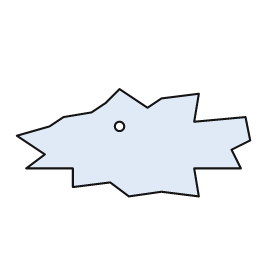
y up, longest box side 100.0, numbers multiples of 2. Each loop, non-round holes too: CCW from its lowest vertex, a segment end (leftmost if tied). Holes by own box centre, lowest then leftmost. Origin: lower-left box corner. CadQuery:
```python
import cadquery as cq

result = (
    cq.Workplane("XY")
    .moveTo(48.0, 0.0)
    .lineTo(62.0, 2.0)
    .lineTo(78.0, 0.0)
    .lineTo(76.0, 12.0)
    .lineTo(96.0, 12.0)
    .lineTo(92.0, 20.0)
    .lineTo(100.0, 24.0)
    .lineTo(98.0, 34.0)
    .lineTo(76.0, 32.0)
    .lineTo(78.0, 44.0)
    .lineTo(62.0, 42.0)
    .lineTo(56.0, 38.0)
    .lineTo(44.0, 46.0)
    .lineTo(38.0, 40.0)
    .lineTo(32.0, 36.0)
    .lineTo(20.0, 34.0)
    .lineTo(14.0, 30.0)
    .lineTo(0.0, 26.0)
    .lineTo(12.0, 18.0)
    .lineTo(4.0, 12.0)
    .lineTo(24.0, 12.0)
    .lineTo(24.0, 4.0)
    .lineTo(40.0, 6.0)
    .close()
    .moveTo(44.0, 30.0)
    .circle(2.0)
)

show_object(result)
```